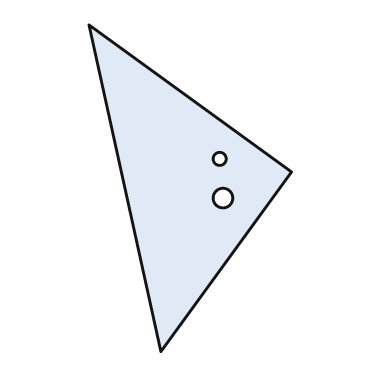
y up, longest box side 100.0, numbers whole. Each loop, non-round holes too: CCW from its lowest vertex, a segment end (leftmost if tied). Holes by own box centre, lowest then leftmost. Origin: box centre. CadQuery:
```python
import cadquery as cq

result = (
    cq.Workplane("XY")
    .moveTo(-9.0, -50.0)
    .lineTo(31.0, 5.0)
    .lineTo(-31.0, 50.0)
    .close()
    .moveTo(10.0, -3.0)
    .circle(3.0)
    .moveTo(9.0, 9.0)
    .circle(2.0)
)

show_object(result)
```